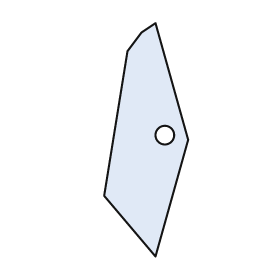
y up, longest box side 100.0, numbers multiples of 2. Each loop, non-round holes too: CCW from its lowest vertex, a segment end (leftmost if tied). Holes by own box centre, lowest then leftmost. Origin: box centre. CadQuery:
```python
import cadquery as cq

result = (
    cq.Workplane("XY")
    .moveTo(4.0, -50.0)
    .lineTo(18.0, 0.0)
    .lineTo(4.0, 50.0)
    .lineTo(-2.0, 46.0)
    .lineTo(-8.0, 38.0)
    .lineTo(-18.0, -24.0)
    .close()
    .moveTo(8.0, 2.0)
    .circle(4.0)
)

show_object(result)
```